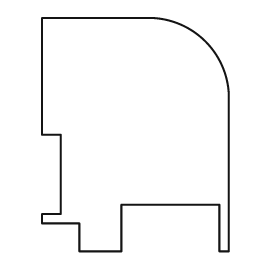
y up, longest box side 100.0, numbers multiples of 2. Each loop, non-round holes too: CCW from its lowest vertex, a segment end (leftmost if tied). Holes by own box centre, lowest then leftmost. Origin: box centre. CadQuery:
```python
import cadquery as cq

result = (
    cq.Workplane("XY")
    .moveTo(-24.0, -50.0)
    .lineTo(-6.0, -50.0)
    .lineTo(-6.0, -30.0)
    .lineTo(36.0, -30.0)
    .lineTo(36.0, -50.0)
    .lineTo(40.0, -50.0)
    .lineTo(40.0, 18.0)
    .threePointArc((30.0, 40.0), (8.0, 50.0))
    .lineTo(-40.0, 50.0)
    .lineTo(-40.0, 0.0)
    .lineTo(-32.0, 0.0)
    .lineTo(-32.0, -34.0)
    .lineTo(-40.0, -34.0)
    .lineTo(-40.0, -38.0)
    .lineTo(-24.0, -38.0)
    .close()
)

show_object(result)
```